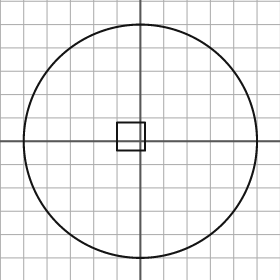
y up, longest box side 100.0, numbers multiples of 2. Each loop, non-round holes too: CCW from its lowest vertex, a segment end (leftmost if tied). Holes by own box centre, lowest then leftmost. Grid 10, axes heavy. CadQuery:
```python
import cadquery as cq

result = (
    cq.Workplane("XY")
    .moveTo(0.0, 0.0)
    .circle(50.0)
    .moveTo(-10.0, -4.0)
    .lineTo(2.0, -4.0)
    .lineTo(2.0, 8.0)
    .lineTo(-10.0, 8.0)
    .close()
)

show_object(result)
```